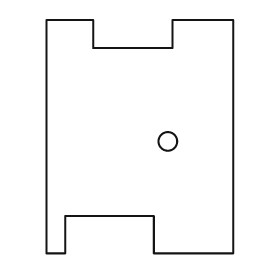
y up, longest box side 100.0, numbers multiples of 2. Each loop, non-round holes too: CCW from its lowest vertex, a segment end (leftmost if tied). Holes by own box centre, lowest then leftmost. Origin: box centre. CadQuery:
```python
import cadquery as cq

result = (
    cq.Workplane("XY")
    .moveTo(-40.0, -50.0)
    .lineTo(-32.0, -50.0)
    .lineTo(-32.0, -34.0)
    .lineTo(6.0, -34.0)
    .lineTo(6.0, -50.0)
    .lineTo(40.0, -50.0)
    .lineTo(40.0, 50.0)
    .lineTo(14.0, 50.0)
    .lineTo(14.0, 38.0)
    .lineTo(-20.0, 38.0)
    .lineTo(-20.0, 50.0)
    .lineTo(-40.0, 50.0)
    .close()
    .moveTo(12.0, -2.0)
    .circle(4.0)
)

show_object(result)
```